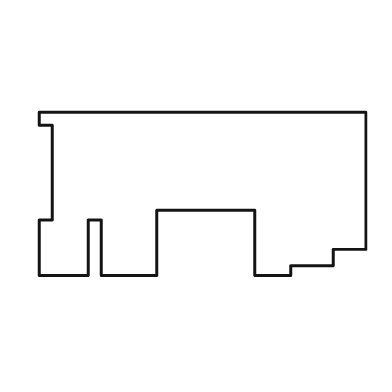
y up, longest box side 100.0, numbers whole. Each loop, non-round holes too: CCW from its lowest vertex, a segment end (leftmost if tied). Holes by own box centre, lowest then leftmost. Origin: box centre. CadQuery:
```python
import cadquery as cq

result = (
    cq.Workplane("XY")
    .moveTo(-50.0, -25.0)
    .lineTo(-35.0, -25.0)
    .lineTo(-35.0, -8.0)
    .lineTo(-31.0, -8.0)
    .lineTo(-31.0, -25.0)
    .lineTo(-14.0, -25.0)
    .lineTo(-14.0, -5.0)
    .lineTo(16.0, -5.0)
    .lineTo(16.0, -25.0)
    .lineTo(27.0, -25.0)
    .lineTo(27.0, -22.0)
    .lineTo(40.0, -22.0)
    .lineTo(40.0, -17.0)
    .lineTo(50.0, -17.0)
    .lineTo(50.0, 25.0)
    .lineTo(-50.0, 25.0)
    .lineTo(-50.0, 21.0)
    .lineTo(-46.0, 21.0)
    .lineTo(-46.0, -8.0)
    .lineTo(-50.0, -8.0)
    .close()
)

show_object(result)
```